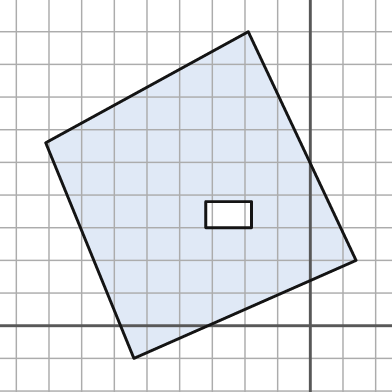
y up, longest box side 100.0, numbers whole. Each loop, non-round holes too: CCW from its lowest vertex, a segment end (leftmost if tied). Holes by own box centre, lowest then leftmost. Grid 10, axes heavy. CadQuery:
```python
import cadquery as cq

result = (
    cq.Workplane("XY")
    .moveTo(-54.0, -10.0)
    .lineTo(14.0, 20.0)
    .lineTo(-19.0, 90.0)
    .lineTo(-81.0, 56.0)
    .close()
    .moveTo(-32.0, 30.0)
    .lineTo(-18.0, 30.0)
    .lineTo(-18.0, 38.0)
    .lineTo(-32.0, 38.0)
    .close()
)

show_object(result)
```